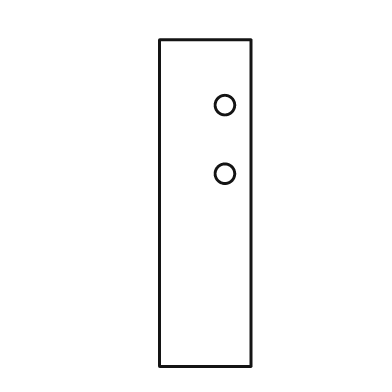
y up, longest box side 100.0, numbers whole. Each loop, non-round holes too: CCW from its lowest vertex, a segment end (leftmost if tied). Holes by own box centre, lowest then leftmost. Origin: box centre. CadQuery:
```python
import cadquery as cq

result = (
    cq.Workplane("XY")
    .moveTo(-14.0, -50.0)
    .lineTo(14.0, -50.0)
    .lineTo(14.0, 50.0)
    .lineTo(-14.0, 50.0)
    .close()
    .moveTo(6.0, 9.0)
    .circle(3.0)
    .moveTo(6.0, 30.0)
    .circle(3.0)
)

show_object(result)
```